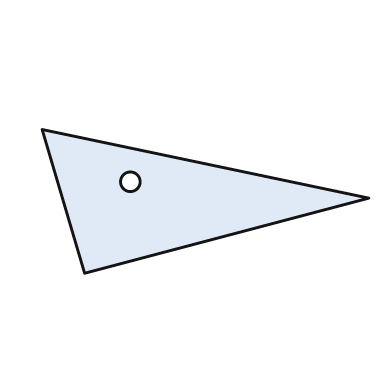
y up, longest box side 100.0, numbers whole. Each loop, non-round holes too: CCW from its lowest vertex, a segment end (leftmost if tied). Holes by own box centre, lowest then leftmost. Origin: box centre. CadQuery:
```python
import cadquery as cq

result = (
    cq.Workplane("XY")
    .moveTo(-37.0, -22.0)
    .lineTo(50.0, 1.0)
    .lineTo(-50.0, 22.0)
    .close()
    .moveTo(-23.0, 6.0)
    .circle(3.0)
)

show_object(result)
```